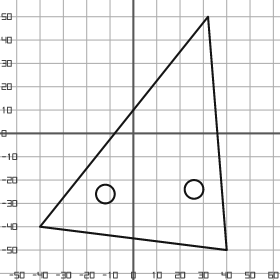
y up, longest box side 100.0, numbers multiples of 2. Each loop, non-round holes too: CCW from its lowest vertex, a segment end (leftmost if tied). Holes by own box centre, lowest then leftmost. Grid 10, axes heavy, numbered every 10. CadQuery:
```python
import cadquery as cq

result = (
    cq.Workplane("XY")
    .moveTo(40.0, -50.0)
    .lineTo(32.0, 50.0)
    .lineTo(-40.0, -40.0)
    .close()
    .moveTo(-12.0, -26.0)
    .circle(4.0)
    .moveTo(26.0, -24.0)
    .circle(4.0)
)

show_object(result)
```